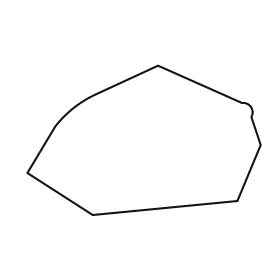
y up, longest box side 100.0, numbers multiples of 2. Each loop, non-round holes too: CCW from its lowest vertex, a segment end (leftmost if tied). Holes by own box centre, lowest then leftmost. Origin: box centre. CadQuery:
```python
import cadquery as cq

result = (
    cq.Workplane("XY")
    .moveTo(-22.0, -32.0)
    .lineTo(40.0, -26.0)
    .lineTo(50.0, -2.0)
    .lineTo(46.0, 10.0)
    .threePointArc((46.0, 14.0), (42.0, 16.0))
    .lineTo(6.0, 32.0)
    .lineTo(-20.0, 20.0)
    .threePointArc((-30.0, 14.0), (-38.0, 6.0))
    .lineTo(-50.0, -14.0)
    .close()
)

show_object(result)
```